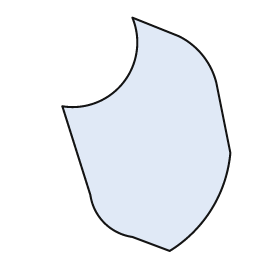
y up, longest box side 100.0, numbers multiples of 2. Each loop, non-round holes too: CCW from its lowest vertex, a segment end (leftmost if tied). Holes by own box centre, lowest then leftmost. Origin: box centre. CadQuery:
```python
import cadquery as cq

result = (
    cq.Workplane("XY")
    .moveTo(10.0, -50.0)
    .threePointArc((28.0, -32.0), (36.0, -8.0))
    .lineTo(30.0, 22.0)
    .threePointArc((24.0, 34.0), (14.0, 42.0))
    .lineTo(-6.0, 50.0)
    .threePointArc((-10.0, 22.0), (-36.0, 12.0))
    .lineTo(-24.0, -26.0)
    .threePointArc((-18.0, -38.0), (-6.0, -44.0))
    .close()
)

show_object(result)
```